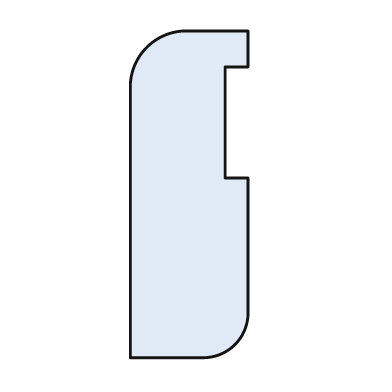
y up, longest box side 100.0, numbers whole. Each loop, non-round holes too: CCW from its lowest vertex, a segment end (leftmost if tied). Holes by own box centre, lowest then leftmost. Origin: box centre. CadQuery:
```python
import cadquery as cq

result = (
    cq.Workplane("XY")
    .moveTo(-18.0, -50.0)
    .lineTo(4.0, -50.0)
    .threePointArc((14.0, -46.0), (18.0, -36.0))
    .lineTo(18.0, 5.0)
    .lineTo(11.0, 5.0)
    .lineTo(11.0, 39.0)
    .lineTo(18.0, 39.0)
    .lineTo(18.0, 50.0)
    .lineTo(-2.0, 50.0)
    .threePointArc((-13.0, 45.0), (-18.0, 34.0))
    .close()
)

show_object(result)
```